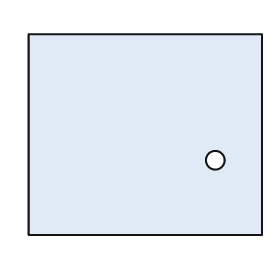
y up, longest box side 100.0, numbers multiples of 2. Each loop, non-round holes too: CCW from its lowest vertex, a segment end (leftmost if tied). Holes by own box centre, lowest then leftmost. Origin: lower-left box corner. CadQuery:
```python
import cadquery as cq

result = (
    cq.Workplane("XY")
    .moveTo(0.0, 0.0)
    .lineTo(100.0, 0.0)
    .lineTo(100.0, 86.0)
    .lineTo(0.0, 86.0)
    .close()
    .moveTo(80.0, 32.0)
    .circle(4.0)
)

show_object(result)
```